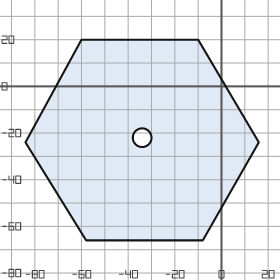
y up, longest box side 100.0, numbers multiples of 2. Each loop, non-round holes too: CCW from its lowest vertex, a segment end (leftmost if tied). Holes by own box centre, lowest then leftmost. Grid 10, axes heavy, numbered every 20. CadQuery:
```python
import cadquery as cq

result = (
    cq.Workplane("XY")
    .moveTo(-58.0, -66.0)
    .lineTo(-8.0, -66.0)
    .lineTo(16.0, -24.0)
    .lineTo(-10.0, 20.0)
    .lineTo(-60.0, 20.0)
    .lineTo(-84.0, -24.0)
    .close()
    .moveTo(-34.0, -22.0)
    .circle(4.0)
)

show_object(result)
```